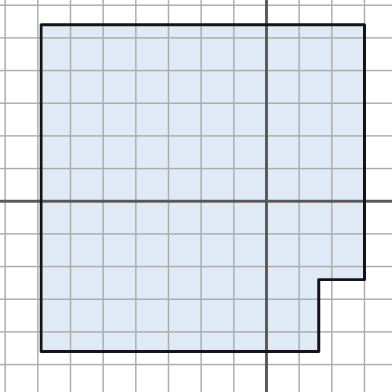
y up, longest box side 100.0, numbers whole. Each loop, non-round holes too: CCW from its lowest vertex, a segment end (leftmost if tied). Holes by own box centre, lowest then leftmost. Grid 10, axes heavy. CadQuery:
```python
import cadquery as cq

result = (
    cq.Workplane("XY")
    .moveTo(-69.0, -46.0)
    .lineTo(16.0, -46.0)
    .lineTo(16.0, -24.0)
    .lineTo(30.0, -24.0)
    .lineTo(30.0, 54.0)
    .lineTo(-69.0, 54.0)
    .close()
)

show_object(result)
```